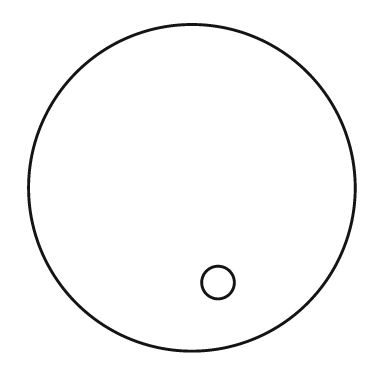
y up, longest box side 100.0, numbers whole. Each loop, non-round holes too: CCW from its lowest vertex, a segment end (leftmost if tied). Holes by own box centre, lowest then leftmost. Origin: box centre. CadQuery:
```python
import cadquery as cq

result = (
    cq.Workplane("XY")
    .moveTo(0.0, 0.0)
    .circle(50.0)
    .moveTo(8.0, -29.0)
    .circle(5.0)
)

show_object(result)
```